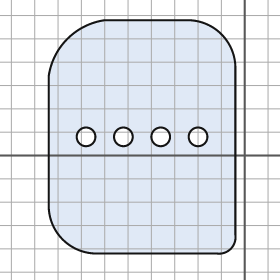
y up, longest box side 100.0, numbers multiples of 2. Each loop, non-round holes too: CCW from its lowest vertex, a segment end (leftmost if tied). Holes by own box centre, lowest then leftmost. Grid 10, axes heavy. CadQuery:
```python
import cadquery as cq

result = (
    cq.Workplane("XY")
    .moveTo(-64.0, -42.0)
    .lineTo(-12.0, -42.0)
    .threePointArc((-6.0, -40.0), (-4.0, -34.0))
    .lineTo(-4.0, 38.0)
    .threePointArc((-10.0, 52.0), (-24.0, 58.0))
    .lineTo(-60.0, 58.0)
    .threePointArc((-76.0, 50.0), (-84.0, 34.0))
    .lineTo(-84.0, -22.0)
    .threePointArc((-78.0, -36.0), (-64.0, -42.0))
    .close()
    .moveTo(-68.0, 8.0)
    .circle(4.0)
    .moveTo(-52.0, 8.0)
    .circle(4.0)
    .moveTo(-36.0, 8.0)
    .circle(4.0)
    .moveTo(-20.0, 8.0)
    .circle(4.0)
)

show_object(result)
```